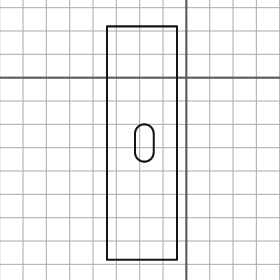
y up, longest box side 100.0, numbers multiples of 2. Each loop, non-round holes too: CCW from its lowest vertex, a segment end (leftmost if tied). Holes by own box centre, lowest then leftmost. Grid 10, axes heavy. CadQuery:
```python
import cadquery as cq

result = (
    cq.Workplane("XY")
    .moveTo(-34.0, -78.0)
    .lineTo(-4.0, -78.0)
    .lineTo(-4.0, 22.0)
    .lineTo(-34.0, 22.0)
    .close()
    .moveTo(-22.0, -32.0)
    .threePointArc((-18.0, -36.0), (-14.0, -32.0))
    .lineTo(-14.0, -24.0)
    .threePointArc((-18.0, -20.0), (-22.0, -24.0))
    .close()
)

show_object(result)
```